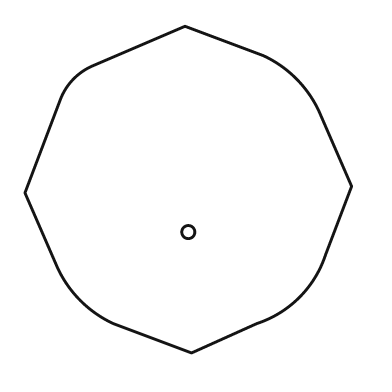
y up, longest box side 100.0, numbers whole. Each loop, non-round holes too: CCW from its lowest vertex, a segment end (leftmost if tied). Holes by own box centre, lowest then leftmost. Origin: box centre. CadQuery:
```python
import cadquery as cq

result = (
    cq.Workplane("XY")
    .moveTo(1.0, -50.0)
    .lineTo(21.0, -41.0)
    .threePointArc((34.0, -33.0), (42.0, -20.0))
    .lineTo(50.0, 1.0)
    .lineTo(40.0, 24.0)
    .threePointArc((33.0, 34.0), (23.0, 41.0))
    .lineTo(-1.0, 50.0)
    .lineTo(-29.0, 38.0)
    .threePointArc((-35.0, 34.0), (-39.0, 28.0))
    .lineTo(-50.0, -1.0)
    .lineTo(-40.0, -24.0)
    .threePointArc((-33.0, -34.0), (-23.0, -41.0))
    .close()
    .moveTo(0.0, -13.0)
    .circle(2.0)
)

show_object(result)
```